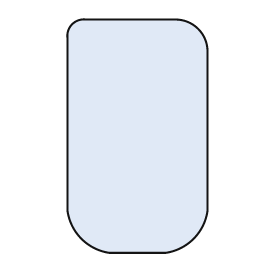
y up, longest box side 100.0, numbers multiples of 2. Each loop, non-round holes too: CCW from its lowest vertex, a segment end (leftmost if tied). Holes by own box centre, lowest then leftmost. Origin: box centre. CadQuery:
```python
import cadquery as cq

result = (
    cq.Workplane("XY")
    .moveTo(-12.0, -50.0)
    .lineTo(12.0, -50.0)
    .threePointArc((24.0, -44.0), (30.0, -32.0))
    .lineTo(30.0, 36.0)
    .threePointArc((26.0, 46.0), (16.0, 50.0))
    .lineTo(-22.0, 50.0)
    .threePointArc((-28.0, 48.0), (-30.0, 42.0))
    .lineTo(-30.0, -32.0)
    .threePointArc((-24.0, -44.0), (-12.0, -50.0))
    .close()
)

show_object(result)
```